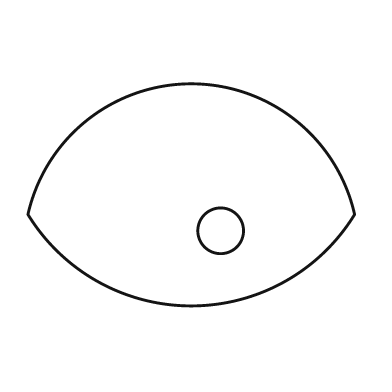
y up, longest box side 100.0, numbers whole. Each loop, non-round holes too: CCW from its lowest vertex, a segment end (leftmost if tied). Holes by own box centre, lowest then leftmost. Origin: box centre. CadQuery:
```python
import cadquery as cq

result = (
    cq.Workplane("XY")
    .moveTo(-50.0, -6.0)
    .threePointArc((0.0, -34.0), (50.0, -6.0))
    .threePointArc((0.0, 34.0), (-50.0, -6.0))
    .close()
    .moveTo(9.0, -11.0)
    .circle(7.0)
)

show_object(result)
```